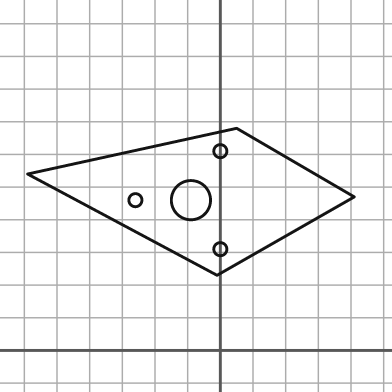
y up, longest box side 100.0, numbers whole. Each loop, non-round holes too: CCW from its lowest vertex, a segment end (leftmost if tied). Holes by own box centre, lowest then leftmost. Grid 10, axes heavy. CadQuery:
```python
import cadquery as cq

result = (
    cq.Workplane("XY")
    .moveTo(-1.0, 23.0)
    .lineTo(41.0, 47.0)
    .lineTo(5.0, 68.0)
    .lineTo(-59.0, 54.0)
    .close()
    .moveTo(0.0, 31.0)
    .circle(2.0)
    .moveTo(-26.0, 46.0)
    .circle(2.0)
    .moveTo(-9.0, 46.0)
    .circle(6.0)
    .moveTo(0.0, 61.0)
    .circle(2.0)
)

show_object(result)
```